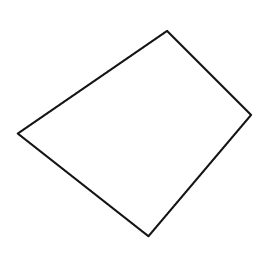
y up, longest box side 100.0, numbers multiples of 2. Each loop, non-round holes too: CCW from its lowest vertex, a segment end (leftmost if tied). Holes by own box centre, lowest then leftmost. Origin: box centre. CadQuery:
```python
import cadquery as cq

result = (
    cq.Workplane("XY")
    .moveTo(6.0, -44.0)
    .lineTo(50.0, 8.0)
    .lineTo(14.0, 44.0)
    .lineTo(-50.0, 0.0)
    .close()
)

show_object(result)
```